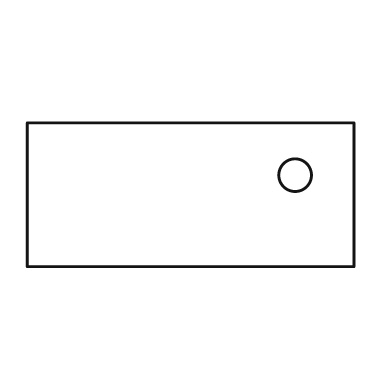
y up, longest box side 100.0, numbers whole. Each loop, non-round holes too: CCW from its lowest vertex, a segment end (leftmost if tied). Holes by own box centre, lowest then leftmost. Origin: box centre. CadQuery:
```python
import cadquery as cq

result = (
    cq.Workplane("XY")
    .moveTo(-50.0, -22.0)
    .lineTo(50.0, -22.0)
    .lineTo(50.0, 22.0)
    .lineTo(-50.0, 22.0)
    .close()
    .moveTo(32.0, 6.0)
    .circle(5.0)
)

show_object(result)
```